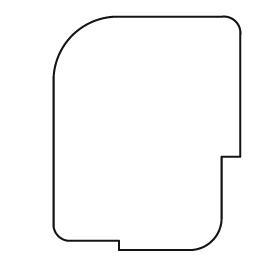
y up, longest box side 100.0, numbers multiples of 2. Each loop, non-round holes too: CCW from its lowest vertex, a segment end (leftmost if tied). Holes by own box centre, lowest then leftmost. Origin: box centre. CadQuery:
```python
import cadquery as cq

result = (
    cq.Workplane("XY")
    .moveTo(-12.0, -50.0)
    .lineTo(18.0, -50.0)
    .threePointArc((28.0, -46.0), (32.0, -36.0))
    .lineTo(32.0, -10.0)
    .lineTo(40.0, -10.0)
    .lineTo(40.0, 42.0)
    .threePointArc((38.0, 48.0), (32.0, 50.0))
    .lineTo(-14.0, 50.0)
    .threePointArc((-32.0, 42.0), (-40.0, 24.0))
    .lineTo(-40.0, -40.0)
    .threePointArc((-38.0, -44.0), (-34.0, -46.0))
    .lineTo(-12.0, -46.0)
    .close()
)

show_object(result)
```